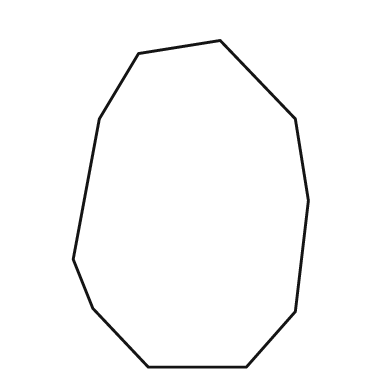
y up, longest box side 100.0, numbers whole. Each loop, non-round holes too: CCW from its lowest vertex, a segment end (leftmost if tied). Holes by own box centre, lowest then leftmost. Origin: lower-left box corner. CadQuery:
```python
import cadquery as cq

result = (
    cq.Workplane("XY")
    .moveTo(23.0, 0.0)
    .lineTo(53.0, 0.0)
    .lineTo(68.0, 17.0)
    .lineTo(72.0, 51.0)
    .lineTo(68.0, 76.0)
    .lineTo(45.0, 100.0)
    .lineTo(20.0, 96.0)
    .lineTo(8.0, 76.0)
    .lineTo(0.0, 33.0)
    .lineTo(6.0, 18.0)
    .close()
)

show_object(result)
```